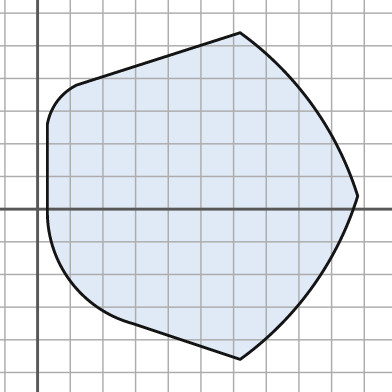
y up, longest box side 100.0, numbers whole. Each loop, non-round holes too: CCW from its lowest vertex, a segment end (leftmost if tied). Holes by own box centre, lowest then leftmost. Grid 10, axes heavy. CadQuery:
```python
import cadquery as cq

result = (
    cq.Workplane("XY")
    .moveTo(62.0, -46.0)
    .threePointArc((84.0, -24.0), (98.0, 4.0))
    .threePointArc((84.0, 32.0), (62.0, 54.0))
    .lineTo(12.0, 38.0)
    .threePointArc((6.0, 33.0), (3.0, 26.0))
    .lineTo(3.0, 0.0)
    .threePointArc((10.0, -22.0), (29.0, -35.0))
    .close()
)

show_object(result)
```